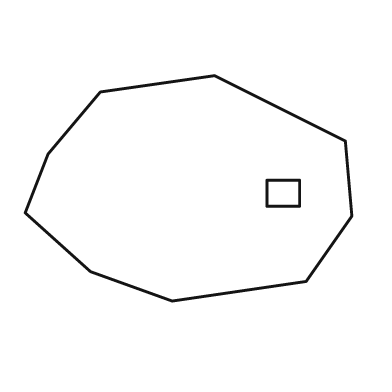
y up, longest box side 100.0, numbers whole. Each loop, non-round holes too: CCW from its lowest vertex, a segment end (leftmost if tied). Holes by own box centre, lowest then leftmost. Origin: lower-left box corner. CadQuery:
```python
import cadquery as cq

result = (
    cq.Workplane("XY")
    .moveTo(45.0, 0.0)
    .lineTo(86.0, 6.0)
    .lineTo(100.0, 26.0)
    .lineTo(98.0, 49.0)
    .lineTo(58.0, 69.0)
    .lineTo(23.0, 64.0)
    .lineTo(7.0, 45.0)
    .lineTo(0.0, 27.0)
    .lineTo(20.0, 9.0)
    .close()
    .moveTo(74.0, 29.0)
    .lineTo(84.0, 29.0)
    .lineTo(84.0, 37.0)
    .lineTo(74.0, 37.0)
    .close()
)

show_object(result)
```